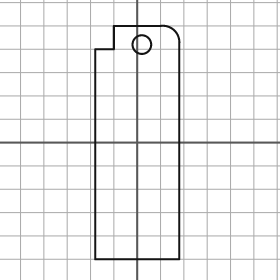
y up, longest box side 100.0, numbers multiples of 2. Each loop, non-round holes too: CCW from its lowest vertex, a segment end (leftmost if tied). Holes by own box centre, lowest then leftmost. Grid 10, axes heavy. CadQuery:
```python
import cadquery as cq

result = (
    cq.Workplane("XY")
    .moveTo(-18.0, -50.0)
    .lineTo(18.0, -50.0)
    .lineTo(18.0, 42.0)
    .threePointArc((16.0, 48.0), (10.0, 50.0))
    .lineTo(-10.0, 50.0)
    .lineTo(-10.0, 40.0)
    .lineTo(-18.0, 40.0)
    .close()
    .moveTo(2.0, 42.0)
    .circle(4.0)
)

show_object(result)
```